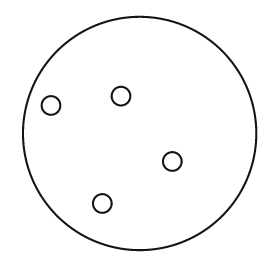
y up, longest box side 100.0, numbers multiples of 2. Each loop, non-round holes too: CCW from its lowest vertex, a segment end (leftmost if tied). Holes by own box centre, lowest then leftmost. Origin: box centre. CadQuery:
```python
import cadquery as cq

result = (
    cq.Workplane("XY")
    .moveTo(0.0, 0.0)
    .circle(50.0)
    .moveTo(-16.0, -30.0)
    .circle(4.0)
    .moveTo(14.0, -12.0)
    .circle(4.0)
    .moveTo(-38.0, 12.0)
    .circle(4.0)
    .moveTo(-8.0, 16.0)
    .circle(4.0)
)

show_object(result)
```